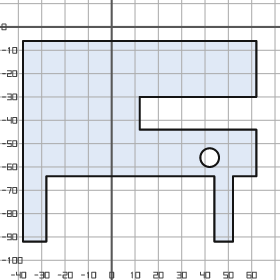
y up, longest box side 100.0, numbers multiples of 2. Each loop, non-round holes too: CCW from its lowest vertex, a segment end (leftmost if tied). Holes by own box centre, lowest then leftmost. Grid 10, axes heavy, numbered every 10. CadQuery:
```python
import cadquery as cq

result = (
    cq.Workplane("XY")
    .moveTo(-38.0, -92.0)
    .lineTo(-28.0, -92.0)
    .lineTo(-28.0, -64.0)
    .lineTo(44.0, -64.0)
    .lineTo(44.0, -92.0)
    .lineTo(52.0, -92.0)
    .lineTo(52.0, -64.0)
    .lineTo(62.0, -64.0)
    .lineTo(62.0, -44.0)
    .lineTo(12.0, -44.0)
    .lineTo(12.0, -30.0)
    .lineTo(62.0, -30.0)
    .lineTo(62.0, -6.0)
    .lineTo(-38.0, -6.0)
    .close()
    .moveTo(42.0, -56.0)
    .circle(4.0)
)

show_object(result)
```